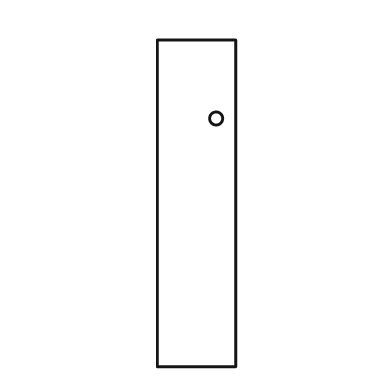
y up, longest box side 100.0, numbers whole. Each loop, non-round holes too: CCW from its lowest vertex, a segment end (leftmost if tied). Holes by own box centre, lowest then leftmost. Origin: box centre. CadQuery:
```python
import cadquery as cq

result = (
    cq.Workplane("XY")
    .moveTo(-12.0, -50.0)
    .lineTo(12.0, -50.0)
    .lineTo(12.0, 50.0)
    .lineTo(-12.0, 50.0)
    .close()
    .moveTo(6.0, 26.0)
    .circle(2.0)
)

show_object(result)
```